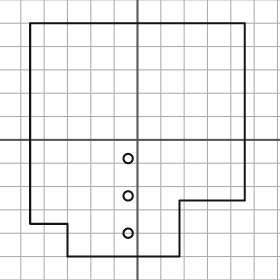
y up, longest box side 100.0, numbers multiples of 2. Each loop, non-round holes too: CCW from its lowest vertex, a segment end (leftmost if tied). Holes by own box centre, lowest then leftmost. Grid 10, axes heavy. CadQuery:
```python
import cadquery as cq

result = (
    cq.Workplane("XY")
    .moveTo(-30.0, -50.0)
    .lineTo(18.0, -50.0)
    .lineTo(18.0, -26.0)
    .lineTo(46.0, -26.0)
    .lineTo(46.0, 50.0)
    .lineTo(-46.0, 50.0)
    .lineTo(-46.0, -36.0)
    .lineTo(-30.0, -36.0)
    .close()
    .moveTo(-4.0, -40.0)
    .circle(2.0)
    .moveTo(-4.0, -24.0)
    .circle(2.0)
    .moveTo(-4.0, -8.0)
    .circle(2.0)
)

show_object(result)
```